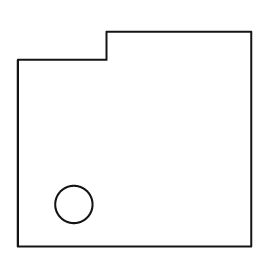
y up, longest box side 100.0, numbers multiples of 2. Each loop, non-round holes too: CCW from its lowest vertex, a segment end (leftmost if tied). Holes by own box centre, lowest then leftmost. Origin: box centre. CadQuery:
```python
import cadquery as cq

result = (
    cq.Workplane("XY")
    .moveTo(-50.0, -46.0)
    .lineTo(50.0, -46.0)
    .lineTo(50.0, 46.0)
    .lineTo(-12.0, 46.0)
    .lineTo(-12.0, 34.0)
    .lineTo(-50.0, 34.0)
    .close()
    .moveTo(-26.0, -28.0)
    .circle(8.0)
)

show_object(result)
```